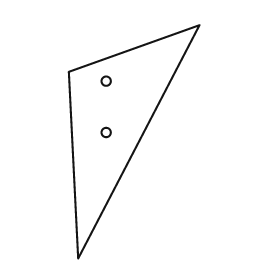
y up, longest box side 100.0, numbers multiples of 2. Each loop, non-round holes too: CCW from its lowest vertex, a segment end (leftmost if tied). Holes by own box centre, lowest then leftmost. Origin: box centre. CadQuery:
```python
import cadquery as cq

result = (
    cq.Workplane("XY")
    .moveTo(-24.0, -50.0)
    .lineTo(28.0, 50.0)
    .lineTo(-28.0, 30.0)
    .close()
    .moveTo(-12.0, 4.0)
    .circle(2.0)
    .moveTo(-12.0, 26.0)
    .circle(2.0)
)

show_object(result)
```